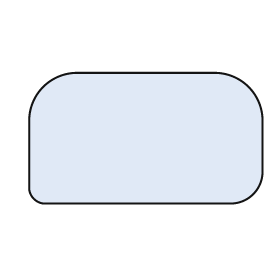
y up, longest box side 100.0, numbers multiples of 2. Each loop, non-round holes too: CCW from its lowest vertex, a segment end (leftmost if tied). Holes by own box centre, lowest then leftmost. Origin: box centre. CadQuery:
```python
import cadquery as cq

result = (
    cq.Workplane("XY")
    .moveTo(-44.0, -28.0)
    .lineTo(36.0, -28.0)
    .threePointArc((46.0, -24.0), (50.0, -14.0))
    .lineTo(50.0, 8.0)
    .threePointArc((44.0, 22.0), (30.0, 28.0))
    .lineTo(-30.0, 28.0)
    .threePointArc((-44.0, 22.0), (-50.0, 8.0))
    .lineTo(-50.0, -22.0)
    .threePointArc((-48.0, -26.0), (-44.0, -28.0))
    .close()
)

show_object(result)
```